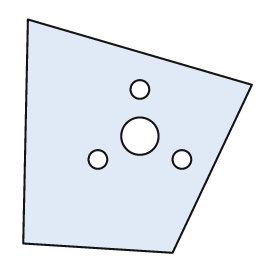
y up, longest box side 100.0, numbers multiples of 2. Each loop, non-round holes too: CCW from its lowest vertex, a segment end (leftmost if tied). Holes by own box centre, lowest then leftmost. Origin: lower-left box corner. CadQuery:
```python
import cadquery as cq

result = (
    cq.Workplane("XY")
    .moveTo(64.0, 0.0)
    .lineTo(98.0, 72.0)
    .lineTo(2.0, 100.0)
    .lineTo(0.0, 4.0)
    .close()
    .moveTo(32.0, 40.0)
    .circle(4.0)
    .moveTo(68.0, 40.0)
    .circle(4.0)
    .moveTo(50.0, 50.0)
    .circle(8.0)
    .moveTo(50.0, 70.0)
    .circle(4.0)
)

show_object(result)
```